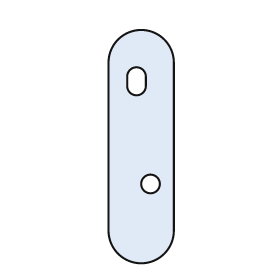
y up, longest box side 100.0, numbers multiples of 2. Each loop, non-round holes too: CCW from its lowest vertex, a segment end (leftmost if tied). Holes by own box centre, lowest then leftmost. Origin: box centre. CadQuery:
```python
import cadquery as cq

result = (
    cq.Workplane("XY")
    .moveTo(-14.0, -36.0)
    .threePointArc((0.0, -50.0), (14.0, -36.0))
    .lineTo(14.0, 36.0)
    .threePointArc((0.0, 50.0), (-14.0, 36.0))
    .close()
    .moveTo(4.0, -16.0)
    .circle(4.0)
    .moveTo(-6.0, 26.0)
    .threePointArc((-2.0, 22.0), (2.0, 26.0))
    .lineTo(2.0, 30.0)
    .threePointArc((-2.0, 34.0), (-6.0, 30.0))
    .close()
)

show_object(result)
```